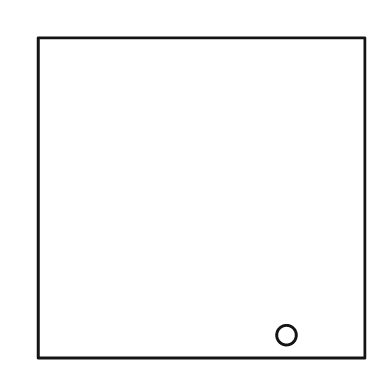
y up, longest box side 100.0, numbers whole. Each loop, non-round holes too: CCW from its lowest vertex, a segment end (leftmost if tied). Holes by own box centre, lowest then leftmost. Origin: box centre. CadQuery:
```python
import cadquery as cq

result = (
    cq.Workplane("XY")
    .moveTo(-50.0, -49.0)
    .lineTo(50.0, -49.0)
    .lineTo(50.0, 49.0)
    .lineTo(-50.0, 49.0)
    .close()
    .moveTo(26.0, -42.0)
    .circle(3.0)
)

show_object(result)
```